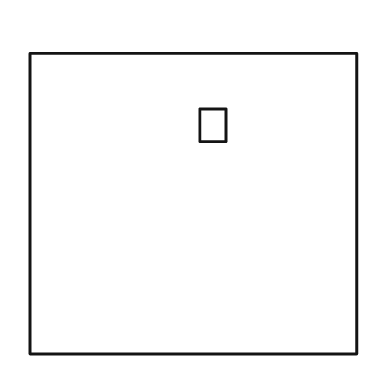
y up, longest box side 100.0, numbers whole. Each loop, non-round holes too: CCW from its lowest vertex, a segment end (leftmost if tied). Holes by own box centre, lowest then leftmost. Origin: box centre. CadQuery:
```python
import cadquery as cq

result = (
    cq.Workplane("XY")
    .moveTo(-50.0, -46.0)
    .lineTo(50.0, -46.0)
    .lineTo(50.0, 46.0)
    .lineTo(-50.0, 46.0)
    .close()
    .moveTo(2.0, 19.0)
    .lineTo(10.0, 19.0)
    .lineTo(10.0, 29.0)
    .lineTo(2.0, 29.0)
    .close()
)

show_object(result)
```